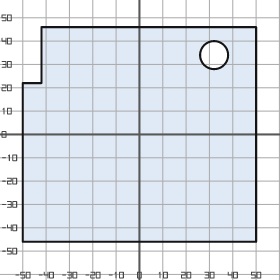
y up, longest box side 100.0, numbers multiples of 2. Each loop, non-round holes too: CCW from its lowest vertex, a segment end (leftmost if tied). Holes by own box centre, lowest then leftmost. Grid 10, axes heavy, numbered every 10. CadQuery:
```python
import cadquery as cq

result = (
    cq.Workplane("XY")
    .moveTo(-50.0, -46.0)
    .lineTo(50.0, -46.0)
    .lineTo(50.0, 46.0)
    .lineTo(-42.0, 46.0)
    .lineTo(-42.0, 22.0)
    .lineTo(-50.0, 22.0)
    .close()
    .moveTo(32.0, 34.0)
    .circle(6.0)
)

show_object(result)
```